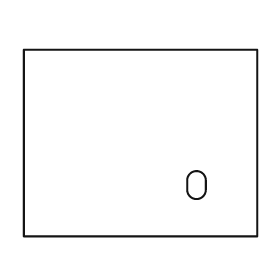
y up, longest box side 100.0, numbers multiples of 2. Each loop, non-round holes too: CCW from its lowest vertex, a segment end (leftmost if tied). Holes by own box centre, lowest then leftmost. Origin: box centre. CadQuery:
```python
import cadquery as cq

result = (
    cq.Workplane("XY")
    .moveTo(-50.0, -40.0)
    .lineTo(50.0, -40.0)
    .lineTo(50.0, 40.0)
    .lineTo(-50.0, 40.0)
    .close()
    .moveTo(20.0, -20.0)
    .threePointArc((24.0, -24.0), (28.0, -20.0))
    .lineTo(28.0, -16.0)
    .threePointArc((24.0, -12.0), (20.0, -16.0))
    .close()
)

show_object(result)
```